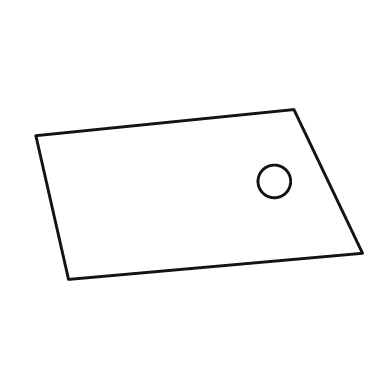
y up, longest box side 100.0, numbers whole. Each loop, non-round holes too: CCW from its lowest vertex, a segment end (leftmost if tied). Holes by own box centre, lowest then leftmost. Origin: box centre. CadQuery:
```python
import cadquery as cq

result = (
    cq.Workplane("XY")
    .moveTo(-40.0, -26.0)
    .lineTo(50.0, -18.0)
    .lineTo(29.0, 26.0)
    .lineTo(-50.0, 18.0)
    .close()
    .moveTo(23.0, 4.0)
    .circle(5.0)
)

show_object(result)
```